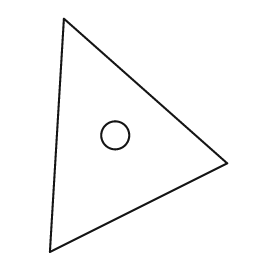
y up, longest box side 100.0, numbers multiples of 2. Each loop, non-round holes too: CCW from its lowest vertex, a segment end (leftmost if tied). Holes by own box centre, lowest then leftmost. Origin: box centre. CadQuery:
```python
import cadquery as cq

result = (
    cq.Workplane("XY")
    .moveTo(-38.0, -50.0)
    .lineTo(38.0, -12.0)
    .lineTo(-32.0, 50.0)
    .close()
    .moveTo(-10.0, 0.0)
    .circle(6.0)
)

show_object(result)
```